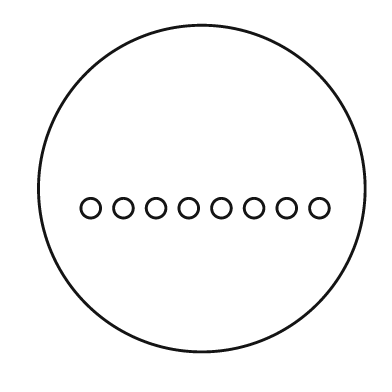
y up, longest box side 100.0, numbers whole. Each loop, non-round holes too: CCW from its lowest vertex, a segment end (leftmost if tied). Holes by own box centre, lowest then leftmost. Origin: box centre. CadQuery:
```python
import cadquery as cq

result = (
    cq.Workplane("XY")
    .moveTo(0.0, 0.0)
    .circle(50.0)
    .moveTo(-34.0, -6.0)
    .circle(3.0)
    .moveTo(-24.0, -6.0)
    .circle(3.0)
    .moveTo(-14.0, -6.0)
    .circle(3.0)
    .moveTo(-4.0, -6.0)
    .circle(3.0)
    .moveTo(6.0, -6.0)
    .circle(3.0)
    .moveTo(16.0, -6.0)
    .circle(3.0)
    .moveTo(26.0, -6.0)
    .circle(3.0)
    .moveTo(36.0, -6.0)
    .circle(3.0)
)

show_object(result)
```